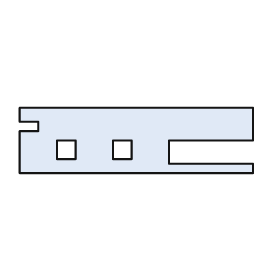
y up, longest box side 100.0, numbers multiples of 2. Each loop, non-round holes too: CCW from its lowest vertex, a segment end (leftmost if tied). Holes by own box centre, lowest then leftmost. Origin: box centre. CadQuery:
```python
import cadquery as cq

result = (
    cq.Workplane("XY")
    .moveTo(-50.0, -14.0)
    .lineTo(50.0, -14.0)
    .lineTo(50.0, -10.0)
    .lineTo(14.0, -10.0)
    .lineTo(14.0, 0.0)
    .lineTo(50.0, 0.0)
    .lineTo(50.0, 14.0)
    .lineTo(-50.0, 14.0)
    .lineTo(-50.0, 8.0)
    .lineTo(-42.0, 8.0)
    .lineTo(-42.0, 4.0)
    .lineTo(-50.0, 4.0)
    .close()
    .moveTo(-34.0, -8.0)
    .lineTo(-26.0, -8.0)
    .lineTo(-26.0, 0.0)
    .lineTo(-34.0, 0.0)
    .close()
    .moveTo(-10.0, -8.0)
    .lineTo(-2.0, -8.0)
    .lineTo(-2.0, 0.0)
    .lineTo(-10.0, 0.0)
    .close()
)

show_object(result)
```